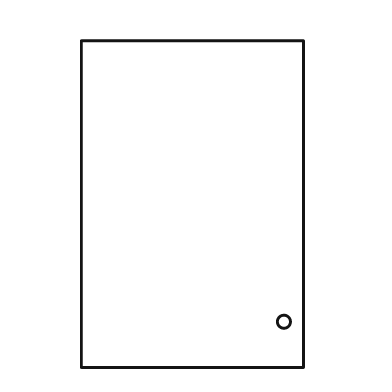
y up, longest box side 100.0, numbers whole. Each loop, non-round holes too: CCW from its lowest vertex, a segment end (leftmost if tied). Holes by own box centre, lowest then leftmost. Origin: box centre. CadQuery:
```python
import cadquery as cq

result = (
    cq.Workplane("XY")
    .moveTo(-34.0, -50.0)
    .lineTo(34.0, -50.0)
    .lineTo(34.0, 50.0)
    .lineTo(-34.0, 50.0)
    .close()
    .moveTo(28.0, -36.0)
    .circle(2.0)
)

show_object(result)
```